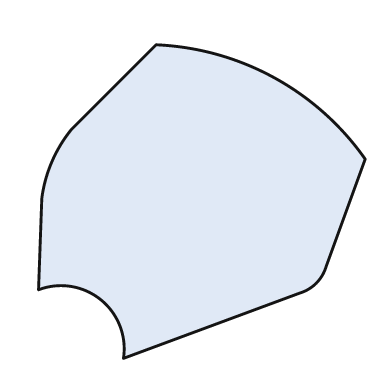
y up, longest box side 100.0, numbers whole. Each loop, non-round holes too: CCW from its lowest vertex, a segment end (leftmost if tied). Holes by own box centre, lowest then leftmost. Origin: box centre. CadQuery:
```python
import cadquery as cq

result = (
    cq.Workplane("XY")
    .moveTo(-24.0, -48.0)
    .lineTo(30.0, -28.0)
    .threePointArc((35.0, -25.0), (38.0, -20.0))
    .lineTo(50.0, 13.0)
    .threePointArc((22.0, 38.0), (-14.0, 48.0))
    .lineTo(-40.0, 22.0)
    .threePointArc((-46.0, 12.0), (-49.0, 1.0))
    .lineTo(-50.0, -27.0)
    .threePointArc((-31.0, -30.0), (-24.0, -48.0))
    .close()
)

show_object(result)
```